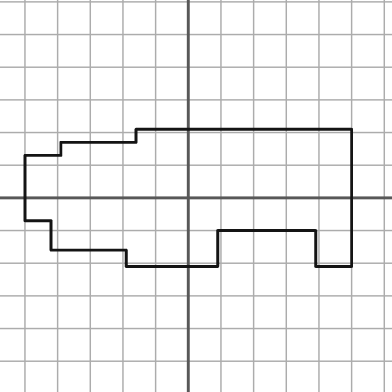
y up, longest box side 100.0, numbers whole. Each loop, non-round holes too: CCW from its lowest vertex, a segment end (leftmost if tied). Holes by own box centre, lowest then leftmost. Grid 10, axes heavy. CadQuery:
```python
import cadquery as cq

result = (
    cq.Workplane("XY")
    .moveTo(-19.0, -21.0)
    .lineTo(9.0, -21.0)
    .lineTo(9.0, -10.0)
    .lineTo(39.0, -10.0)
    .lineTo(39.0, -21.0)
    .lineTo(50.0, -21.0)
    .lineTo(50.0, 21.0)
    .lineTo(-16.0, 21.0)
    .lineTo(-16.0, 17.0)
    .lineTo(-39.0, 17.0)
    .lineTo(-39.0, 13.0)
    .lineTo(-50.0, 13.0)
    .lineTo(-50.0, -7.0)
    .lineTo(-42.0, -7.0)
    .lineTo(-42.0, -16.0)
    .lineTo(-19.0, -16.0)
    .close()
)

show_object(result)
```